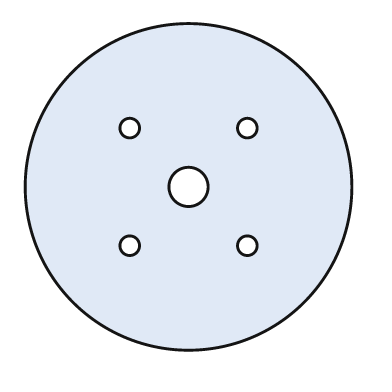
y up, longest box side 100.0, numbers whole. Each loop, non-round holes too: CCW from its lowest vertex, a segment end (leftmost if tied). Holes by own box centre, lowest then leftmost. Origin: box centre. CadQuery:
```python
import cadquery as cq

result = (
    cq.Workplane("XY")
    .moveTo(0.0, 0.0)
    .circle(50.0)
    .moveTo(-18.0, -18.0)
    .circle(3.0)
    .moveTo(18.0, -18.0)
    .circle(3.0)
    .moveTo(0.0, 0.0)
    .circle(6.0)
    .moveTo(-18.0, 18.0)
    .circle(3.0)
    .moveTo(18.0, 18.0)
    .circle(3.0)
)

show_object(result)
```